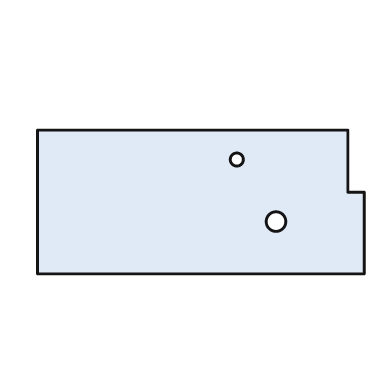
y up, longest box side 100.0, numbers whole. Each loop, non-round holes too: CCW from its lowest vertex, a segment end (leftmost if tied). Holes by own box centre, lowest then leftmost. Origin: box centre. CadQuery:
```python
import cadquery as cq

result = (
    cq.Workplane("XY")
    .moveTo(-50.0, -22.0)
    .lineTo(50.0, -22.0)
    .lineTo(50.0, 3.0)
    .lineTo(45.0, 3.0)
    .lineTo(45.0, 22.0)
    .lineTo(-50.0, 22.0)
    .close()
    .moveTo(23.0, -6.0)
    .circle(3.0)
    .moveTo(11.0, 13.0)
    .circle(2.0)
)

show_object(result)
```